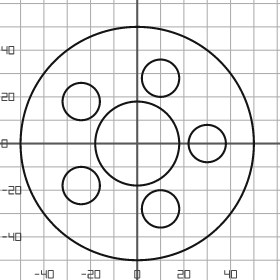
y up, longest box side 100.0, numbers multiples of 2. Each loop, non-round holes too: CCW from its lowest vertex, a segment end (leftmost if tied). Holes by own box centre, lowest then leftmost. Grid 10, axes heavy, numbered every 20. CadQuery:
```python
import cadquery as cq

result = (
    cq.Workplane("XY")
    .moveTo(0.0, 0.0)
    .circle(50.0)
    .moveTo(10.0, -28.0)
    .circle(8.0)
    .moveTo(-24.0, -18.0)
    .circle(8.0)
    .moveTo(0.0, 0.0)
    .circle(18.0)
    .moveTo(30.0, 0.0)
    .circle(8.0)
    .moveTo(-24.0, 18.0)
    .circle(8.0)
    .moveTo(10.0, 28.0)
    .circle(8.0)
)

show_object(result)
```